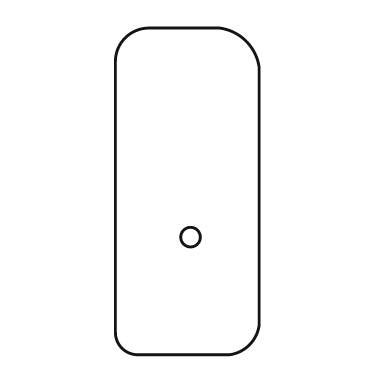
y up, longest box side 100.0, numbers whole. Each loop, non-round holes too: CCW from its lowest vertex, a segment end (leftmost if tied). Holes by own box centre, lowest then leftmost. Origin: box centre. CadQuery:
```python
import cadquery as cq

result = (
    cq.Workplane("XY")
    .moveTo(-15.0, -50.0)
    .lineTo(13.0, -50.0)
    .threePointArc((19.0, -47.0), (22.0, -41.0))
    .lineTo(22.0, 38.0)
    .threePointArc((18.0, 46.0), (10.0, 50.0))
    .lineTo(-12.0, 50.0)
    .threePointArc((-19.0, 47.0), (-22.0, 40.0))
    .lineTo(-22.0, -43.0)
    .threePointArc((-20.0, -48.0), (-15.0, -50.0))
    .close()
    .moveTo(1.0, -14.0)
    .circle(3.0)
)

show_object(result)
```